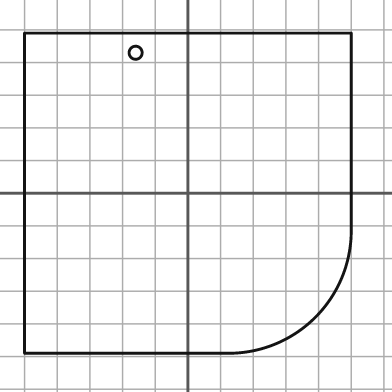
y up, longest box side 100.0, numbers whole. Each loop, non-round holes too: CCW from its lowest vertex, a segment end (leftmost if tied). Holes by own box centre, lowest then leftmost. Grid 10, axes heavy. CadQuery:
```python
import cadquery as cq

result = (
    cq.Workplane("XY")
    .moveTo(-50.0, -49.0)
    .lineTo(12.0, -49.0)
    .threePointArc((39.0, -38.0), (50.0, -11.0))
    .lineTo(50.0, 49.0)
    .lineTo(-50.0, 49.0)
    .close()
    .moveTo(-16.0, 43.0)
    .circle(2.0)
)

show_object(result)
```